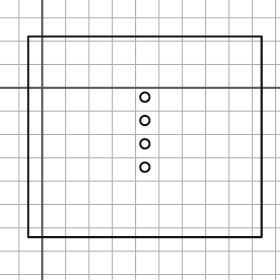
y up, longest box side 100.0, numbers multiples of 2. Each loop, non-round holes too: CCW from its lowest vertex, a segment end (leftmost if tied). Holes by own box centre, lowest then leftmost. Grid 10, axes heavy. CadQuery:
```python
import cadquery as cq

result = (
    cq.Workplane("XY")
    .moveTo(-6.0, -64.0)
    .lineTo(94.0, -64.0)
    .lineTo(94.0, 22.0)
    .lineTo(-6.0, 22.0)
    .close()
    .moveTo(44.0, -34.0)
    .circle(2.0)
    .moveTo(44.0, -24.0)
    .circle(2.0)
    .moveTo(44.0, -14.0)
    .circle(2.0)
    .moveTo(44.0, -4.0)
    .circle(2.0)
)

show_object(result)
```